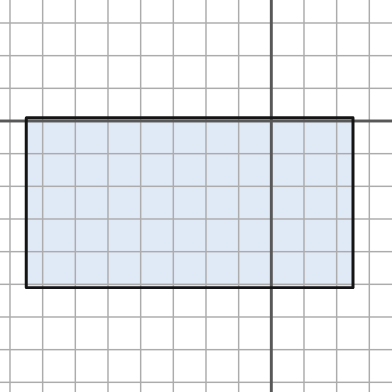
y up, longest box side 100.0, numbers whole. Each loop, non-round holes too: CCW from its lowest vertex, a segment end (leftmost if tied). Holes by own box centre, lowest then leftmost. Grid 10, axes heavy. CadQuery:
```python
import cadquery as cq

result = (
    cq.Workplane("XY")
    .moveTo(-75.0, -51.0)
    .lineTo(25.0, -51.0)
    .lineTo(25.0, 1.0)
    .lineTo(-75.0, 1.0)
    .close()
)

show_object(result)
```